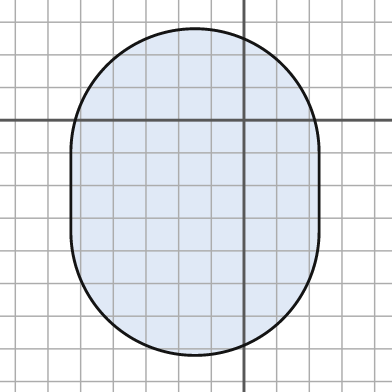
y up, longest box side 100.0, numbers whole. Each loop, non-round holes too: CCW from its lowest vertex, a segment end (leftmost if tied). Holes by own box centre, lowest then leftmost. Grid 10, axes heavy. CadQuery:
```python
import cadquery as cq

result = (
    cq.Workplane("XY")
    .moveTo(-53.0, -34.0)
    .threePointArc((-15.0, -72.0), (23.0, -34.0))
    .lineTo(23.0, -10.0)
    .threePointArc((-15.0, 28.0), (-53.0, -10.0))
    .close()
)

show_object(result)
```